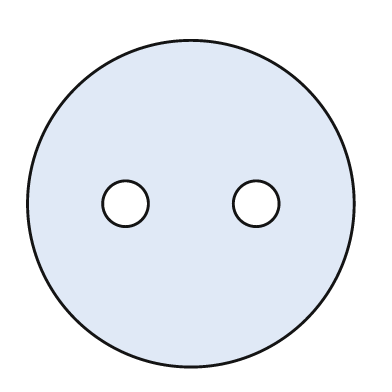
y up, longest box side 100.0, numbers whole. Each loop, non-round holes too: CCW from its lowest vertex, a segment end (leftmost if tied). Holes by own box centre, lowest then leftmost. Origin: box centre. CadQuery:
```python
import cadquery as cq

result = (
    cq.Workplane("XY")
    .moveTo(0.0, 0.0)
    .circle(50.0)
    .moveTo(-20.0, 0.0)
    .circle(7.0)
    .moveTo(20.0, 0.0)
    .circle(7.0)
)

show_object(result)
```